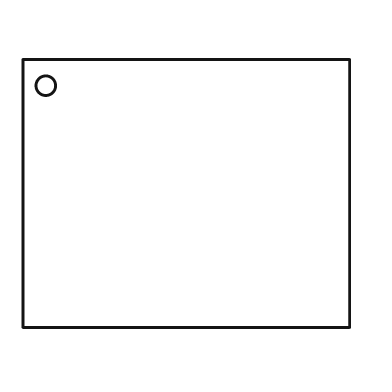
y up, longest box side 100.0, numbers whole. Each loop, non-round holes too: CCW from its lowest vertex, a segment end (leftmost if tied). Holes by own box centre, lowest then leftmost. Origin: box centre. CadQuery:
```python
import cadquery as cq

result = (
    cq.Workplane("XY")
    .moveTo(-50.0, -41.0)
    .lineTo(50.0, -41.0)
    .lineTo(50.0, 41.0)
    .lineTo(-50.0, 41.0)
    .close()
    .moveTo(-43.0, 33.0)
    .circle(3.0)
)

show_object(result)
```